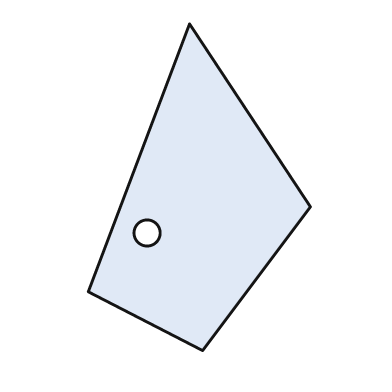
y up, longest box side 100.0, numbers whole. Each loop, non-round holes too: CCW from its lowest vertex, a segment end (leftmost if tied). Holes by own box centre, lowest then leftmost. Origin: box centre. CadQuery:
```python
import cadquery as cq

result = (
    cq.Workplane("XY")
    .moveTo(1.0, -50.0)
    .lineTo(34.0, -6.0)
    .lineTo(-3.0, 50.0)
    .lineTo(-34.0, -32.0)
    .close()
    .moveTo(-16.0, -14.0)
    .circle(4.0)
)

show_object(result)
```